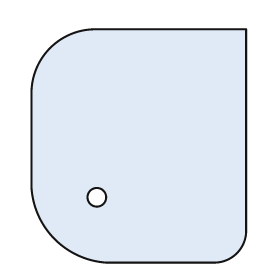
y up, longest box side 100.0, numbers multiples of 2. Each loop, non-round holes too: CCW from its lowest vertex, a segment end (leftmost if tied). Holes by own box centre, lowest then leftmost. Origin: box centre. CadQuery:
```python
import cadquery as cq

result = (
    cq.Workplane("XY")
    .moveTo(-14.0, -50.0)
    .lineTo(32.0, -50.0)
    .threePointArc((42.0, -46.0), (46.0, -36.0))
    .lineTo(46.0, 50.0)
    .lineTo(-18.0, 50.0)
    .threePointArc((-38.0, 42.0), (-46.0, 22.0))
    .lineTo(-46.0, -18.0)
    .threePointArc((-36.0, -40.0), (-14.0, -50.0))
    .close()
    .moveTo(-18.0, -22.0)
    .circle(4.0)
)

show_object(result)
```